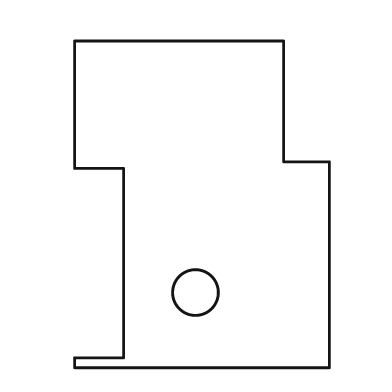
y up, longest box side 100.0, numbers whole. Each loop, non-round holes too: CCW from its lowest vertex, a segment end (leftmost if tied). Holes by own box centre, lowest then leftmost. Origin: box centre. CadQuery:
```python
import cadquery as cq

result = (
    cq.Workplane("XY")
    .moveTo(-39.0, -50.0)
    .lineTo(39.0, -50.0)
    .lineTo(39.0, 13.0)
    .lineTo(25.0, 13.0)
    .lineTo(25.0, 50.0)
    .lineTo(-39.0, 50.0)
    .lineTo(-39.0, 11.0)
    .lineTo(-24.0, 11.0)
    .lineTo(-24.0, -47.0)
    .lineTo(-39.0, -47.0)
    .close()
    .moveTo(-2.0, -27.0)
    .circle(7.0)
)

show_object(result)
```